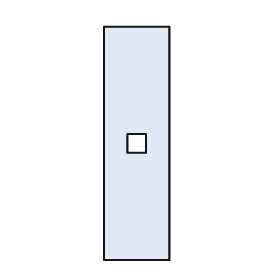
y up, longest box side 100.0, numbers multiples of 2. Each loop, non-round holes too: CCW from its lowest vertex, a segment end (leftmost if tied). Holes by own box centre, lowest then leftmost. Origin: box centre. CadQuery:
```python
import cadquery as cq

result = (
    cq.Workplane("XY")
    .moveTo(-14.0, -50.0)
    .lineTo(14.0, -50.0)
    .lineTo(14.0, 50.0)
    .lineTo(-14.0, 50.0)
    .close()
    .moveTo(-4.0, -4.0)
    .lineTo(4.0, -4.0)
    .lineTo(4.0, 4.0)
    .lineTo(-4.0, 4.0)
    .close()
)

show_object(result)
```